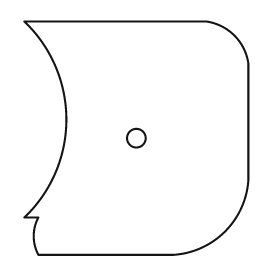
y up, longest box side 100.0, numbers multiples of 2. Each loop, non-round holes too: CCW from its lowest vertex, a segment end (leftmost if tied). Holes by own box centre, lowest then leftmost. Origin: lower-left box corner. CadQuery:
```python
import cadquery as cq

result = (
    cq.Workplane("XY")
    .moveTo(6.0, 0.0)
    .lineTo(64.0, 0.0)
    .threePointArc((86.0, 10.0), (96.0, 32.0))
    .lineTo(96.0, 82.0)
    .threePointArc((90.0, 94.0), (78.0, 100.0))
    .lineTo(0.0, 100.0)
    .threePointArc((18.0, 58.0), (0.0, 16.0))
    .lineTo(6.0, 16.0)
    .threePointArc((4.0, 8.0), (6.0, 0.0))
    .close()
    .moveTo(48.0, 50.0)
    .circle(4.0)
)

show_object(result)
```